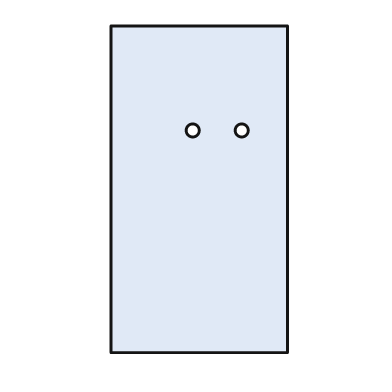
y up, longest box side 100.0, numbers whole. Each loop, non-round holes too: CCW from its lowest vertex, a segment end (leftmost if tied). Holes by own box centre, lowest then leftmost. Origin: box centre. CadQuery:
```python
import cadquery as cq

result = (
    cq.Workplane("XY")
    .moveTo(-27.0, -50.0)
    .lineTo(27.0, -50.0)
    .lineTo(27.0, 50.0)
    .lineTo(-27.0, 50.0)
    .close()
    .moveTo(-2.0, 18.0)
    .circle(2.0)
    .moveTo(13.0, 18.0)
    .circle(2.0)
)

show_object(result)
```